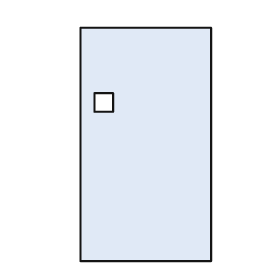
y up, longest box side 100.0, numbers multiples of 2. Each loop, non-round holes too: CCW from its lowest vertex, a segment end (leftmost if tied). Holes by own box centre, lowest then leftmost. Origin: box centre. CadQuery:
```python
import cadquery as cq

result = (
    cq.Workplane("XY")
    .moveTo(-28.0, -50.0)
    .lineTo(28.0, -50.0)
    .lineTo(28.0, 50.0)
    .lineTo(-28.0, 50.0)
    .close()
    .moveTo(-22.0, 14.0)
    .lineTo(-14.0, 14.0)
    .lineTo(-14.0, 22.0)
    .lineTo(-22.0, 22.0)
    .close()
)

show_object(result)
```